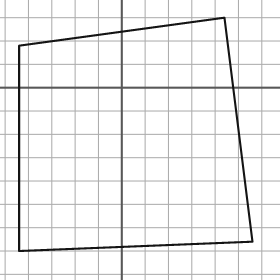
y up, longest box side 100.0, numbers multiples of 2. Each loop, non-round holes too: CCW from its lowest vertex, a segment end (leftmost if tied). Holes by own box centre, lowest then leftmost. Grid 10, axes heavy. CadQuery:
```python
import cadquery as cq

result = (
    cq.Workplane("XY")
    .moveTo(-44.0, -70.0)
    .lineTo(56.0, -66.0)
    .lineTo(44.0, 30.0)
    .lineTo(-44.0, 18.0)
    .close()
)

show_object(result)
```